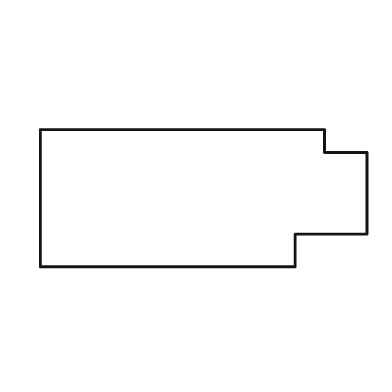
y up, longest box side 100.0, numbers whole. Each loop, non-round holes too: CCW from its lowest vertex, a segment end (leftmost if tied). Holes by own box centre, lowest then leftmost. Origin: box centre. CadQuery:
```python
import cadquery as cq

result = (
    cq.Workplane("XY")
    .moveTo(-50.0, -21.0)
    .lineTo(28.0, -21.0)
    .lineTo(28.0, -11.0)
    .lineTo(50.0, -11.0)
    .lineTo(50.0, 14.0)
    .lineTo(37.0, 14.0)
    .lineTo(37.0, 21.0)
    .lineTo(-50.0, 21.0)
    .close()
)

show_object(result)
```